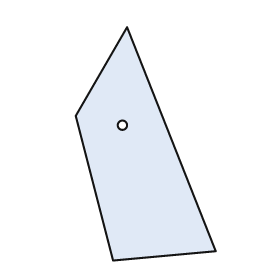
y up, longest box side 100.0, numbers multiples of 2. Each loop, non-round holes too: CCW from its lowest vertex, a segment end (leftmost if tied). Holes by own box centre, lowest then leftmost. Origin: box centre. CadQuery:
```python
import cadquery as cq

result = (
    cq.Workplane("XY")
    .moveTo(-14.0, -50.0)
    .lineTo(30.0, -46.0)
    .lineTo(-8.0, 50.0)
    .lineTo(-30.0, 12.0)
    .close()
    .moveTo(-10.0, 8.0)
    .circle(2.0)
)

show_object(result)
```